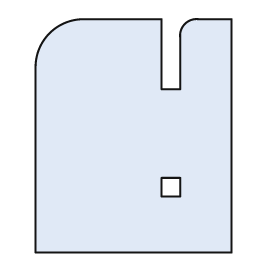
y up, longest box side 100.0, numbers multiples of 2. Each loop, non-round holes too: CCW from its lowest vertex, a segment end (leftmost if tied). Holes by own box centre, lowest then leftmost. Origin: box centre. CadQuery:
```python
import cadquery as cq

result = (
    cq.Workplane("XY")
    .moveTo(-42.0, -50.0)
    .lineTo(42.0, -50.0)
    .lineTo(42.0, 50.0)
    .lineTo(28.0, 50.0)
    .threePointArc((22.0, 48.0), (20.0, 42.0))
    .lineTo(20.0, 20.0)
    .lineTo(12.0, 20.0)
    .lineTo(12.0, 50.0)
    .lineTo(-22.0, 50.0)
    .threePointArc((-36.0, 44.0), (-42.0, 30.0))
    .close()
    .moveTo(12.0, -26.0)
    .lineTo(20.0, -26.0)
    .lineTo(20.0, -18.0)
    .lineTo(12.0, -18.0)
    .close()
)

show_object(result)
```